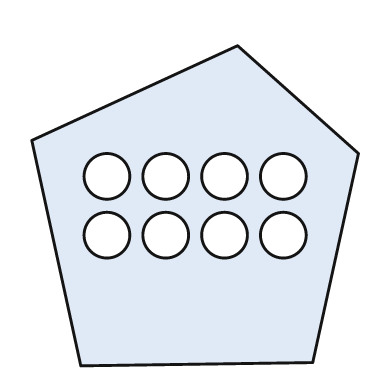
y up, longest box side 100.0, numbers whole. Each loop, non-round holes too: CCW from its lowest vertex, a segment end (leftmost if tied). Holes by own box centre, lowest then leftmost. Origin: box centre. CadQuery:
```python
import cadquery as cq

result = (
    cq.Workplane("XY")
    .moveTo(-35.0, -49.0)
    .lineTo(36.0, -48.0)
    .lineTo(50.0, 16.0)
    .lineTo(13.0, 49.0)
    .lineTo(-50.0, 20.0)
    .close()
    .moveTo(-27.0, -9.0)
    .circle(7.0)
    .moveTo(-9.0, -9.0)
    .circle(7.0)
    .moveTo(9.0, -9.0)
    .circle(7.0)
    .moveTo(27.0, -9.0)
    .circle(7.0)
    .moveTo(-27.0, 9.0)
    .circle(7.0)
    .moveTo(-9.0, 9.0)
    .circle(7.0)
    .moveTo(9.0, 9.0)
    .circle(7.0)
    .moveTo(27.0, 9.0)
    .circle(7.0)
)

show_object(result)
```